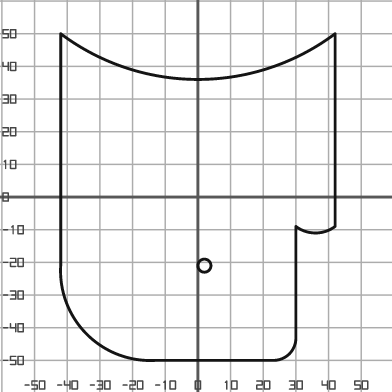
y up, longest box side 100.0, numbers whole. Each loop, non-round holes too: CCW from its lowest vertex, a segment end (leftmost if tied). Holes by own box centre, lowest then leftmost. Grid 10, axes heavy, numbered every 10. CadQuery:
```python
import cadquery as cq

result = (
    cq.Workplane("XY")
    .moveTo(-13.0, -50.0)
    .lineTo(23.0, -50.0)
    .threePointArc((28.0, -48.0), (30.0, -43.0))
    .lineTo(30.0, -9.0)
    .threePointArc((36.0, -11.0), (42.0, -9.0))
    .lineTo(42.0, 50.0)
    .threePointArc((0.0, 36.0), (-42.0, 50.0))
    .lineTo(-42.0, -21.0)
    .threePointArc((-34.0, -42.0), (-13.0, -50.0))
    .close()
    .moveTo(2.0, -21.0)
    .circle(2.0)
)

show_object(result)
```